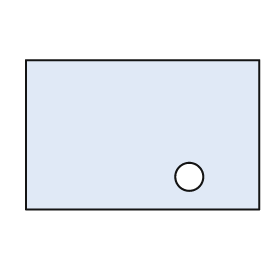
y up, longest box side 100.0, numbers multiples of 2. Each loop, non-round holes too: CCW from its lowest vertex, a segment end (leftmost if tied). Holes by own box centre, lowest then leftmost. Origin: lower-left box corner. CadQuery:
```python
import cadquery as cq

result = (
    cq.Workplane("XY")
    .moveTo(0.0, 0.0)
    .lineTo(100.0, 0.0)
    .lineTo(100.0, 64.0)
    .lineTo(0.0, 64.0)
    .close()
    .moveTo(70.0, 14.0)
    .circle(6.0)
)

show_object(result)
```